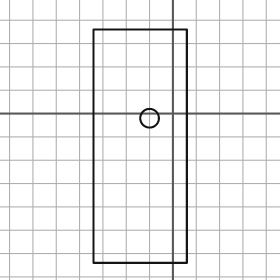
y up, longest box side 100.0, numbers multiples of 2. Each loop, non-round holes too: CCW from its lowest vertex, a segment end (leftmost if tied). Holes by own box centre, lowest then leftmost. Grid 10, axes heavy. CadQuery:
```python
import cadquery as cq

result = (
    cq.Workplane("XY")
    .moveTo(-34.0, -64.0)
    .lineTo(6.0, -64.0)
    .lineTo(6.0, 36.0)
    .lineTo(-34.0, 36.0)
    .close()
    .moveTo(-10.0, -2.0)
    .circle(4.0)
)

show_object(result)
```